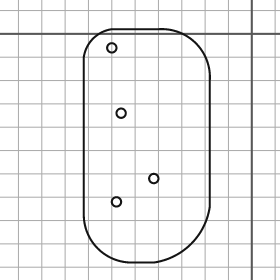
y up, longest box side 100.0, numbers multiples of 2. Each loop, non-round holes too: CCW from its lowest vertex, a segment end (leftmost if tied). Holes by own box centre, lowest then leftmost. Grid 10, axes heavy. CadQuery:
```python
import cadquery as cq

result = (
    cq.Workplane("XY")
    .moveTo(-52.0, -98.0)
    .lineTo(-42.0, -98.0)
    .threePointArc((-26.0, -90.0), (-18.0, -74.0))
    .lineTo(-18.0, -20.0)
    .threePointArc((-24.0, -4.0), (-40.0, 2.0))
    .lineTo(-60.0, 2.0)
    .threePointArc((-68.0, -2.0), (-72.0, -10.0))
    .lineTo(-72.0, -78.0)
    .threePointArc((-66.0, -92.0), (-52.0, -98.0))
    .close()
    .moveTo(-58.0, -72.0)
    .circle(2.0)
    .moveTo(-42.0, -62.0)
    .circle(2.0)
    .moveTo(-56.0, -34.0)
    .circle(2.0)
    .moveTo(-60.0, -6.0)
    .circle(2.0)
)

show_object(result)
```